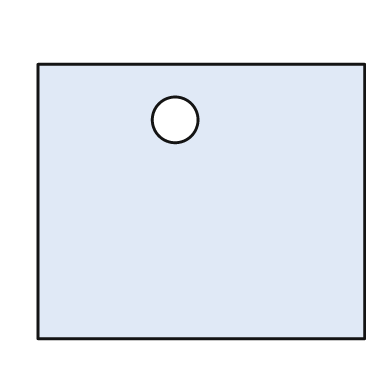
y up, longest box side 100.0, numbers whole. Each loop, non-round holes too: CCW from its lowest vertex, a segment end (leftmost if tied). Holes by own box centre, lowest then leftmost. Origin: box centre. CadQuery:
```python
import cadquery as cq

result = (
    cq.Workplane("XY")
    .moveTo(-50.0, -42.0)
    .lineTo(50.0, -42.0)
    .lineTo(50.0, 42.0)
    .lineTo(-50.0, 42.0)
    .close()
    .moveTo(-8.0, 25.0)
    .circle(7.0)
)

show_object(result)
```